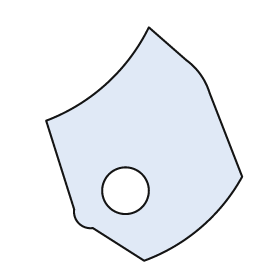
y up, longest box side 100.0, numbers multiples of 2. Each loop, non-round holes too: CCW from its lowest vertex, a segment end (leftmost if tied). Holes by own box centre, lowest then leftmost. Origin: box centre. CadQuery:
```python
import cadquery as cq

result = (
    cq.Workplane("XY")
    .moveTo(0.0, -50.0)
    .threePointArc((24.0, -36.0), (42.0, -14.0))
    .lineTo(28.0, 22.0)
    .threePointArc((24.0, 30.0), (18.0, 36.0))
    .lineTo(2.0, 50.0)
    .threePointArc((-16.0, 26.0), (-42.0, 10.0))
    .lineTo(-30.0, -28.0)
    .threePointArc((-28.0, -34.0), (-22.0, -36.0))
    .close()
    .moveTo(-8.0, -20.0)
    .circle(10.0)
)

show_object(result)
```